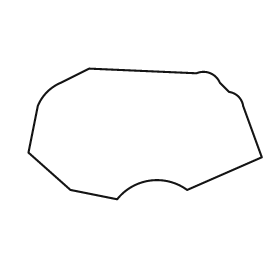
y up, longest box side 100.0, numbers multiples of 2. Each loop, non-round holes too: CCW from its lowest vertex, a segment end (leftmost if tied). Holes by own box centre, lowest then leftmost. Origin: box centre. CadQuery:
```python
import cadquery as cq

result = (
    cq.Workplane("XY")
    .moveTo(-12.0, -28.0)
    .threePointArc((2.0, -20.0), (18.0, -24.0))
    .lineTo(50.0, -10.0)
    .lineTo(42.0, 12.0)
    .threePointArc((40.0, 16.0), (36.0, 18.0))
    .lineTo(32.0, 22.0)
    .threePointArc((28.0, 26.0), (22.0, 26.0))
    .lineTo(-24.0, 28.0)
    .lineTo(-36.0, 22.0)
    .threePointArc((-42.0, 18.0), (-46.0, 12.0))
    .lineTo(-50.0, -8.0)
    .lineTo(-32.0, -24.0)
    .close()
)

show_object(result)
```